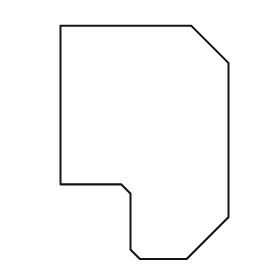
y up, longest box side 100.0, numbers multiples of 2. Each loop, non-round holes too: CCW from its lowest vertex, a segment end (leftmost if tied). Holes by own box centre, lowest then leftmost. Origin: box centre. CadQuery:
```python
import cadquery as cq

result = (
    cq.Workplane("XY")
    .moveTo(-2.0, -50.0)
    .lineTo(18.0, -50.0)
    .lineTo(36.0, -32.0)
    .lineTo(36.0, 34.0)
    .lineTo(20.0, 50.0)
    .lineTo(-36.0, 50.0)
    .lineTo(-36.0, -18.0)
    .lineTo(-10.0, -18.0)
    .lineTo(-6.0, -22.0)
    .lineTo(-6.0, -46.0)
    .close()
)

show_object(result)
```